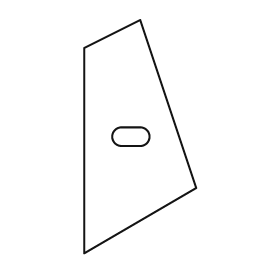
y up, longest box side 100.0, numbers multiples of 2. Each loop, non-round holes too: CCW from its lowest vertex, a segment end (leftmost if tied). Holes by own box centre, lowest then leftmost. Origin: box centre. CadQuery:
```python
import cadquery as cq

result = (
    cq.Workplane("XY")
    .moveTo(-24.0, -50.0)
    .lineTo(24.0, -22.0)
    .lineTo(0.0, 50.0)
    .lineTo(-24.0, 38.0)
    .close()
    .moveTo(-8.0, -4.0)
    .lineTo(0.0, -4.0)
    .threePointArc((4.0, 0.0), (0.0, 4.0))
    .lineTo(-8.0, 4.0)
    .threePointArc((-12.0, 0.0), (-8.0, -4.0))
    .close()
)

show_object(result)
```